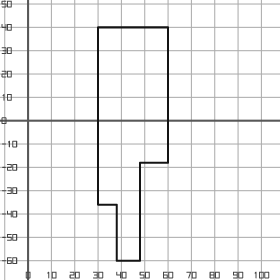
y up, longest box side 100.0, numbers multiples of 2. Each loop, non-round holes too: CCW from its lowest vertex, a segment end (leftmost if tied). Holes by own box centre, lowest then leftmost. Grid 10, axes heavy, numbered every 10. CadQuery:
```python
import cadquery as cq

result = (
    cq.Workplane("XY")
    .moveTo(38.0, -60.0)
    .lineTo(48.0, -60.0)
    .lineTo(48.0, -18.0)
    .lineTo(60.0, -18.0)
    .lineTo(60.0, 40.0)
    .lineTo(30.0, 40.0)
    .lineTo(30.0, -36.0)
    .lineTo(38.0, -36.0)
    .close()
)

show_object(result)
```